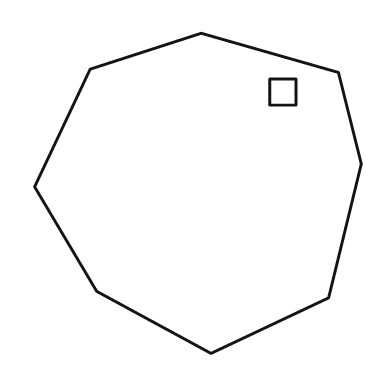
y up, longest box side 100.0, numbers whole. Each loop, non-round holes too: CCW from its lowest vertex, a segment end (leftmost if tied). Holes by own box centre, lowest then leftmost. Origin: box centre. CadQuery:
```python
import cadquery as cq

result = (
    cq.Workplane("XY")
    .moveTo(4.0, -49.0)
    .lineTo(40.0, -32.0)
    .lineTo(50.0, 9.0)
    .lineTo(43.0, 37.0)
    .lineTo(1.0, 49.0)
    .lineTo(-33.0, 38.0)
    .lineTo(-50.0, 2.0)
    .lineTo(-31.0, -30.0)
    .close()
    .moveTo(22.0, 27.0)
    .lineTo(30.0, 27.0)
    .lineTo(30.0, 35.0)
    .lineTo(22.0, 35.0)
    .close()
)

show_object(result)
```